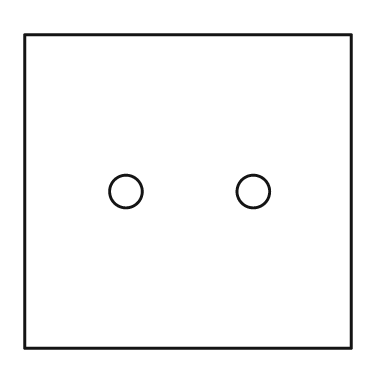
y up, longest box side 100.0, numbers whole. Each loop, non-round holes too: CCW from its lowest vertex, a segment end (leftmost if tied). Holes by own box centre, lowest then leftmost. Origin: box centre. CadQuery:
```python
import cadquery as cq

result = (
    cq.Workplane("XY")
    .moveTo(-50.0, -48.0)
    .lineTo(50.0, -48.0)
    .lineTo(50.0, 48.0)
    .lineTo(-50.0, 48.0)
    .close()
    .moveTo(-19.0, 0.0)
    .circle(5.0)
    .moveTo(20.0, 0.0)
    .circle(5.0)
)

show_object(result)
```